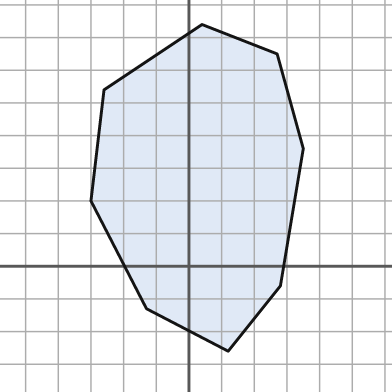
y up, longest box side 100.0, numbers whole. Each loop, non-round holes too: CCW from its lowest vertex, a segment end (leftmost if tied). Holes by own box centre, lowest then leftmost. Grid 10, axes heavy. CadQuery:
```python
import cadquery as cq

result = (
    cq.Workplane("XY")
    .moveTo(12.0, -26.0)
    .lineTo(28.0, -6.0)
    .lineTo(35.0, 36.0)
    .lineTo(27.0, 65.0)
    .lineTo(4.0, 74.0)
    .lineTo(-26.0, 54.0)
    .lineTo(-30.0, 20.0)
    .lineTo(-13.0, -13.0)
    .close()
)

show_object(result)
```